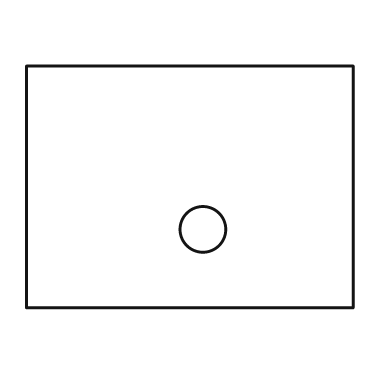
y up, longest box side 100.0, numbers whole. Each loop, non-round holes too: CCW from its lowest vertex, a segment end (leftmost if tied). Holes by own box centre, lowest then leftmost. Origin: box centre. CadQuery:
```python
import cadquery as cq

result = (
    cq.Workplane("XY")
    .moveTo(-50.0, -37.0)
    .lineTo(50.0, -37.0)
    .lineTo(50.0, 37.0)
    .lineTo(-50.0, 37.0)
    .close()
    .moveTo(4.0, -13.0)
    .circle(7.0)
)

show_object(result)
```